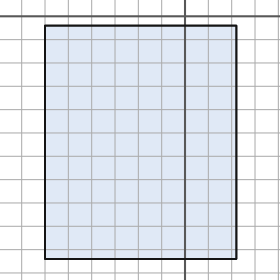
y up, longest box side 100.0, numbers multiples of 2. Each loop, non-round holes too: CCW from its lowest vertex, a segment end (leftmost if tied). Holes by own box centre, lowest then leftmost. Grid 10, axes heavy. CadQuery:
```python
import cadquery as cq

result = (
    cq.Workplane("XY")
    .moveTo(-60.0, -104.0)
    .lineTo(22.0, -104.0)
    .lineTo(22.0, -4.0)
    .lineTo(-60.0, -4.0)
    .close()
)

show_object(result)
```